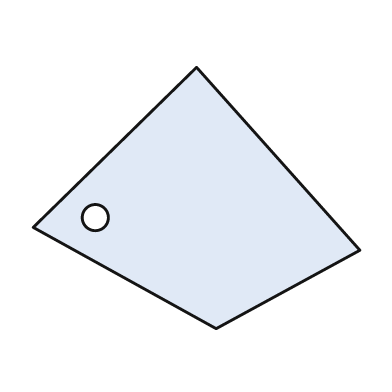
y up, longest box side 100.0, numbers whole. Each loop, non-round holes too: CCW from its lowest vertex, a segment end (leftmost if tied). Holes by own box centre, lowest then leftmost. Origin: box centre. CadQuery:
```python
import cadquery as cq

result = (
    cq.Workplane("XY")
    .moveTo(6.0, -40.0)
    .lineTo(50.0, -16.0)
    .lineTo(0.0, 40.0)
    .lineTo(-50.0, -9.0)
    .close()
    .moveTo(-31.0, -6.0)
    .circle(4.0)
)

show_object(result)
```